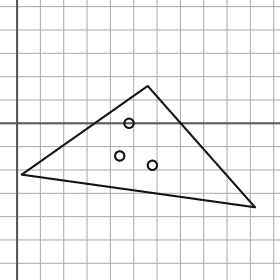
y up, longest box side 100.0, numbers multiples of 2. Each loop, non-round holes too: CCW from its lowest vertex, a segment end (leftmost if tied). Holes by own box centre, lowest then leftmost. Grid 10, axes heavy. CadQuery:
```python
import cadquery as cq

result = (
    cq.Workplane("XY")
    .moveTo(102.0, -36.0)
    .lineTo(56.0, 16.0)
    .lineTo(2.0, -22.0)
    .close()
    .moveTo(58.0, -18.0)
    .circle(2.0)
    .moveTo(44.0, -14.0)
    .circle(2.0)
    .moveTo(48.0, 0.0)
    .circle(2.0)
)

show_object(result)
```